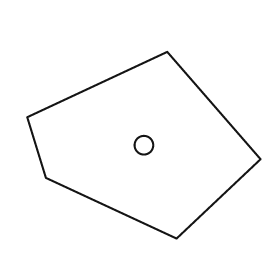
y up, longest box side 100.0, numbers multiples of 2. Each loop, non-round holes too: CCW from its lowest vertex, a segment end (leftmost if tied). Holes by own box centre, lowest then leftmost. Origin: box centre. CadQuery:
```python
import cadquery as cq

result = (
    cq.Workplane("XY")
    .moveTo(14.0, -40.0)
    .lineTo(50.0, -6.0)
    .lineTo(10.0, 40.0)
    .lineTo(-50.0, 12.0)
    .lineTo(-42.0, -14.0)
    .close()
    .moveTo(0.0, 0.0)
    .circle(4.0)
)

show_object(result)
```